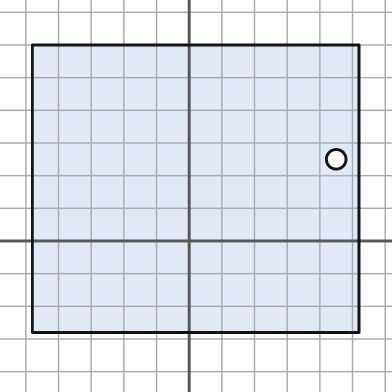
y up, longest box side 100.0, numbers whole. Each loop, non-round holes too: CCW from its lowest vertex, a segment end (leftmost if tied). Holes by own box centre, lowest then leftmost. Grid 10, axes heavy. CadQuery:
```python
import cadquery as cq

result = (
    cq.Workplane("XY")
    .moveTo(-48.0, -28.0)
    .lineTo(52.0, -28.0)
    .lineTo(52.0, 60.0)
    .lineTo(-48.0, 60.0)
    .close()
    .moveTo(45.0, 25.0)
    .circle(3.0)
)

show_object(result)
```